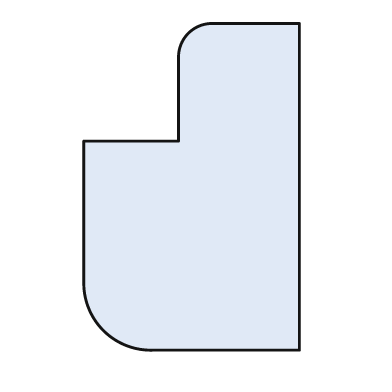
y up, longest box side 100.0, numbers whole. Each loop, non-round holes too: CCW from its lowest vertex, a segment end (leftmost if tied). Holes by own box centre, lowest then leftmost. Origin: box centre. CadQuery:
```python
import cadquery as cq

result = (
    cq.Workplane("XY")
    .moveTo(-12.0, -50.0)
    .lineTo(33.0, -50.0)
    .lineTo(33.0, 50.0)
    .lineTo(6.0, 50.0)
    .threePointArc((-1.0, 47.0), (-4.0, 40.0))
    .lineTo(-4.0, 14.0)
    .lineTo(-33.0, 14.0)
    .lineTo(-33.0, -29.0)
    .threePointArc((-27.0, -44.0), (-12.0, -50.0))
    .close()
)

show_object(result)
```